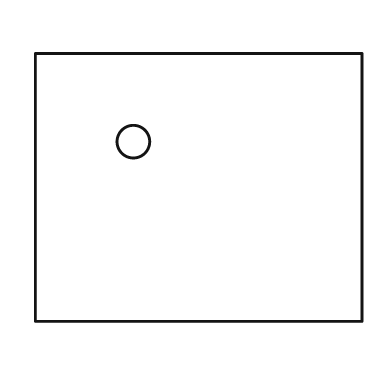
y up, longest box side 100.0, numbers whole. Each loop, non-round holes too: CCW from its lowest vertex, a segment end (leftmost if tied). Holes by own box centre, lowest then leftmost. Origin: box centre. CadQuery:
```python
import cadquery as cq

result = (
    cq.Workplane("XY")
    .moveTo(-50.0, -41.0)
    .lineTo(50.0, -41.0)
    .lineTo(50.0, 41.0)
    .lineTo(-50.0, 41.0)
    .close()
    .moveTo(-20.0, 14.0)
    .circle(5.0)
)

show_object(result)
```